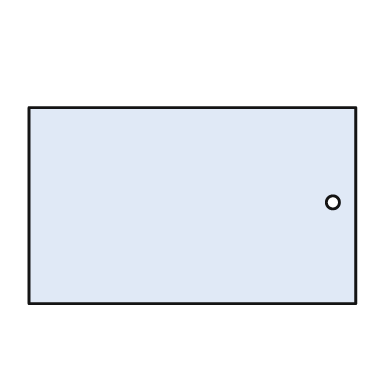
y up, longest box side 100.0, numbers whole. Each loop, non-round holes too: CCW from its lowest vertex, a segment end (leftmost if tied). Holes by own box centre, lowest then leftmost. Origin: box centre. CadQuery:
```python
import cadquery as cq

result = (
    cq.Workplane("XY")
    .moveTo(-50.0, -30.0)
    .lineTo(50.0, -30.0)
    .lineTo(50.0, 30.0)
    .lineTo(-50.0, 30.0)
    .close()
    .moveTo(43.0, 1.0)
    .circle(2.0)
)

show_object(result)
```